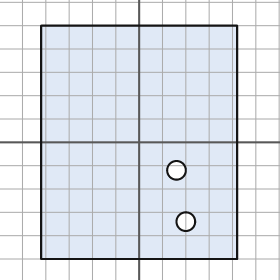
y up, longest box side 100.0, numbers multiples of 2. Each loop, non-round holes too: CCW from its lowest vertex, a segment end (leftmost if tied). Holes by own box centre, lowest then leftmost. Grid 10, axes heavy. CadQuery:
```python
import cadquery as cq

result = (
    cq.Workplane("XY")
    .moveTo(-42.0, -50.0)
    .lineTo(42.0, -50.0)
    .lineTo(42.0, 50.0)
    .lineTo(-42.0, 50.0)
    .close()
    .moveTo(20.0, -34.0)
    .circle(4.0)
    .moveTo(16.0, -12.0)
    .circle(4.0)
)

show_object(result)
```